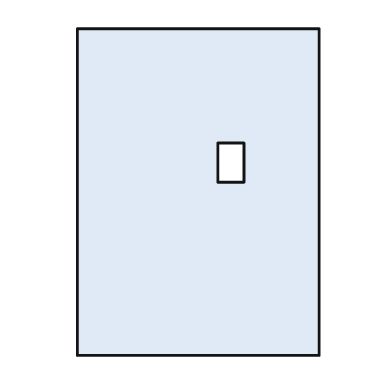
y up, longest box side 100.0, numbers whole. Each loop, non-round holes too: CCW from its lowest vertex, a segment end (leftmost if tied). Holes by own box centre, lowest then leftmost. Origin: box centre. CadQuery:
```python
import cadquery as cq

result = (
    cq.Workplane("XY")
    .moveTo(-37.0, -50.0)
    .lineTo(37.0, -50.0)
    .lineTo(37.0, 50.0)
    .lineTo(-37.0, 50.0)
    .close()
    .moveTo(6.0, 3.0)
    .lineTo(14.0, 3.0)
    .lineTo(14.0, 15.0)
    .lineTo(6.0, 15.0)
    .close()
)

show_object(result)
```